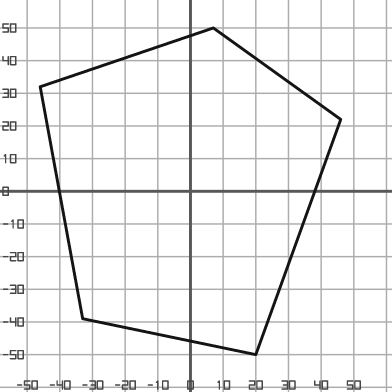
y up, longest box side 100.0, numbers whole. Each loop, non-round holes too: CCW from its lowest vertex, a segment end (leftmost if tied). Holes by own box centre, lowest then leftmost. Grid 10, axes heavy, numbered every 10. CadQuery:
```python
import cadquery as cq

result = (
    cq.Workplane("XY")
    .moveTo(20.0, -50.0)
    .lineTo(46.0, 22.0)
    .lineTo(7.0, 50.0)
    .lineTo(-46.0, 32.0)
    .lineTo(-33.0, -39.0)
    .close()
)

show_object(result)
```